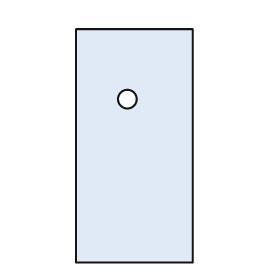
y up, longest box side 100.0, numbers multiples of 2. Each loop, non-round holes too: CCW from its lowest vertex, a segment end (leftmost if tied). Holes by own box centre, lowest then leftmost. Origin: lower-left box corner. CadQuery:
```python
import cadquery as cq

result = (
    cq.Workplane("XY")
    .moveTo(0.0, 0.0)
    .lineTo(50.0, 0.0)
    .lineTo(50.0, 100.0)
    .lineTo(0.0, 100.0)
    .close()
    .moveTo(22.0, 70.0)
    .circle(4.0)
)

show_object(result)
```